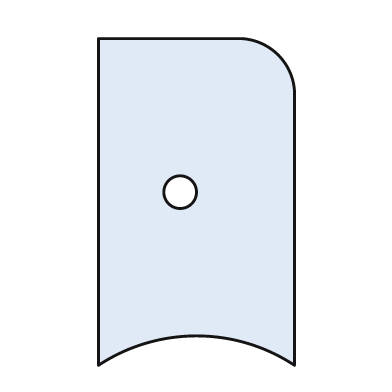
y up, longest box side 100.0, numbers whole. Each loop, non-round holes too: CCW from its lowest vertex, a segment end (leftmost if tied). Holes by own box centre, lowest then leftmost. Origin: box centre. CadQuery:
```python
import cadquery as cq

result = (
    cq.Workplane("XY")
    .moveTo(-30.0, -50.0)
    .threePointArc((0.0, -41.0), (30.0, -50.0))
    .lineTo(30.0, 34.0)
    .threePointArc((25.0, 45.0), (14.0, 50.0))
    .lineTo(-30.0, 50.0)
    .close()
    .moveTo(-5.0, 3.0)
    .circle(5.0)
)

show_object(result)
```